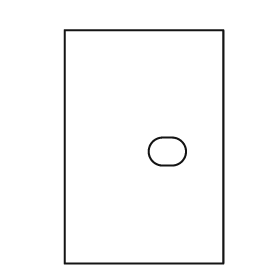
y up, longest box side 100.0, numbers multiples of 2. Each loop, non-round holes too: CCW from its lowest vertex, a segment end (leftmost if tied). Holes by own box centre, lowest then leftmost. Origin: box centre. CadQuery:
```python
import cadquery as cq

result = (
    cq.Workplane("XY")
    .moveTo(-34.0, -50.0)
    .lineTo(34.0, -50.0)
    .lineTo(34.0, 50.0)
    .lineTo(-34.0, 50.0)
    .close()
    .moveTo(8.0, -8.0)
    .lineTo(12.0, -8.0)
    .threePointArc((18.0, -2.0), (12.0, 4.0))
    .lineTo(8.0, 4.0)
    .threePointArc((2.0, -2.0), (8.0, -8.0))
    .close()
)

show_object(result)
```